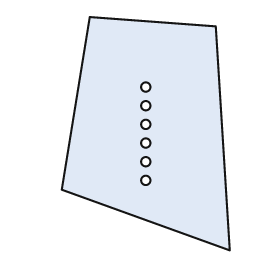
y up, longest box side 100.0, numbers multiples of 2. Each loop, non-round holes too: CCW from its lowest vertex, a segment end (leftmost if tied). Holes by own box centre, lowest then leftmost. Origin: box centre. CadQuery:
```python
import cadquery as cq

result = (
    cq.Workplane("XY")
    .moveTo(36.0, -50.0)
    .lineTo(30.0, 46.0)
    .lineTo(-24.0, 50.0)
    .lineTo(-36.0, -24.0)
    .close()
    .moveTo(0.0, -20.0)
    .circle(2.0)
    .moveTo(0.0, -12.0)
    .circle(2.0)
    .moveTo(0.0, -4.0)
    .circle(2.0)
    .moveTo(0.0, 4.0)
    .circle(2.0)
    .moveTo(0.0, 12.0)
    .circle(2.0)
    .moveTo(0.0, 20.0)
    .circle(2.0)
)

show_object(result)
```